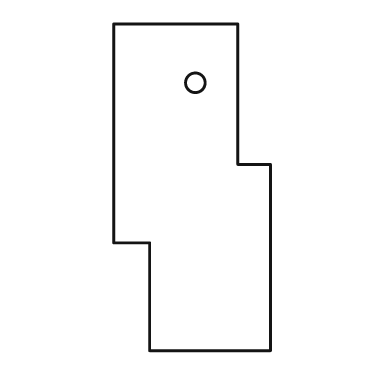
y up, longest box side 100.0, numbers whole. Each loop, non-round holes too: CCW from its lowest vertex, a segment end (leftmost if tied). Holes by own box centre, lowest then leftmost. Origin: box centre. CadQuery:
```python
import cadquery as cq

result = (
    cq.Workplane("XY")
    .moveTo(-13.0, -50.0)
    .lineTo(24.0, -50.0)
    .lineTo(24.0, 7.0)
    .lineTo(14.0, 7.0)
    .lineTo(14.0, 50.0)
    .lineTo(-24.0, 50.0)
    .lineTo(-24.0, -17.0)
    .lineTo(-13.0, -17.0)
    .close()
    .moveTo(1.0, 32.0)
    .circle(3.0)
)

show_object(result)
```